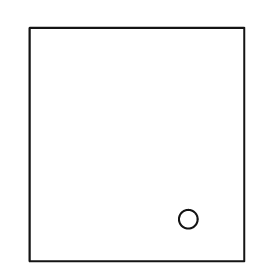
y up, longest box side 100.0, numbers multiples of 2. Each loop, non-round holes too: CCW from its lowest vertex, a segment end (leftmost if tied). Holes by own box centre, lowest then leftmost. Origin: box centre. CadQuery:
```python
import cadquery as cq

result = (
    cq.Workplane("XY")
    .moveTo(-46.0, -50.0)
    .lineTo(46.0, -50.0)
    .lineTo(46.0, 50.0)
    .lineTo(-46.0, 50.0)
    .close()
    .moveTo(22.0, -32.0)
    .circle(4.0)
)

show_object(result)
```